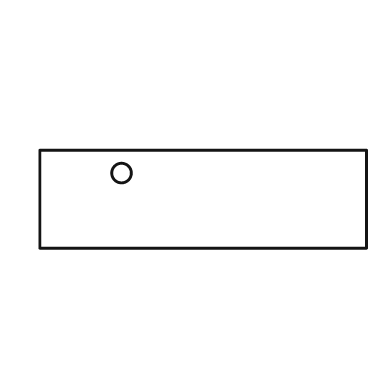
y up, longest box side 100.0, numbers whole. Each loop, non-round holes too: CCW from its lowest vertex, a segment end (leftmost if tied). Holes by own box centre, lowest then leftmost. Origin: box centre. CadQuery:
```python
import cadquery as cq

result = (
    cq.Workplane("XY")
    .moveTo(-50.0, -15.0)
    .lineTo(50.0, -15.0)
    .lineTo(50.0, 15.0)
    .lineTo(-50.0, 15.0)
    .close()
    .moveTo(-25.0, 8.0)
    .circle(3.0)
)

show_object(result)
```